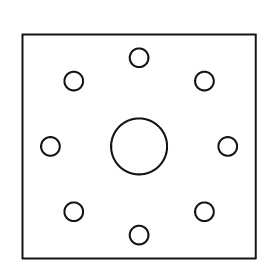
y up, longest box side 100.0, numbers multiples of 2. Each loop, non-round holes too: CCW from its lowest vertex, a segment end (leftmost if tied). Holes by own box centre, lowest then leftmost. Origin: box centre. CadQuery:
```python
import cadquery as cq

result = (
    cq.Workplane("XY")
    .moveTo(-50.0, -48.0)
    .lineTo(50.0, -48.0)
    .lineTo(50.0, 48.0)
    .lineTo(-50.0, 48.0)
    .close()
    .moveTo(0.0, -38.0)
    .circle(4.0)
    .moveTo(-28.0, -28.0)
    .circle(4.0)
    .moveTo(28.0, -28.0)
    .circle(4.0)
    .moveTo(-38.0, 0.0)
    .circle(4.0)
    .moveTo(0.0, 0.0)
    .circle(12.0)
    .moveTo(38.0, 0.0)
    .circle(4.0)
    .moveTo(-28.0, 28.0)
    .circle(4.0)
    .moveTo(28.0, 28.0)
    .circle(4.0)
    .moveTo(0.0, 38.0)
    .circle(4.0)
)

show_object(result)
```